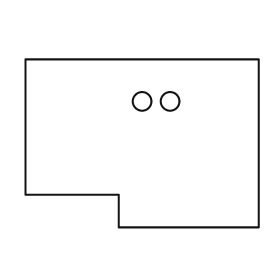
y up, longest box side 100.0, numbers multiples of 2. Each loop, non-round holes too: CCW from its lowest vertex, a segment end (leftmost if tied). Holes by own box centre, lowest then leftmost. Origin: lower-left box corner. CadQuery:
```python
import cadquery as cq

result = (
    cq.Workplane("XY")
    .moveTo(40.0, 0.0)
    .lineTo(100.0, 0.0)
    .lineTo(100.0, 72.0)
    .lineTo(0.0, 72.0)
    .lineTo(0.0, 14.0)
    .lineTo(40.0, 14.0)
    .close()
    .moveTo(50.0, 54.0)
    .circle(4.0)
    .moveTo(62.0, 54.0)
    .circle(4.0)
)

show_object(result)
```